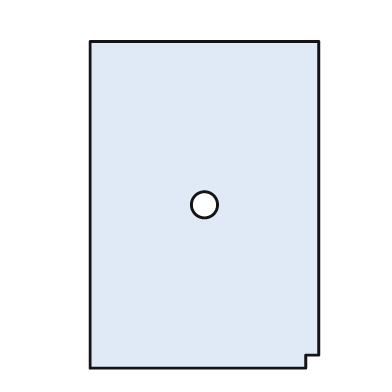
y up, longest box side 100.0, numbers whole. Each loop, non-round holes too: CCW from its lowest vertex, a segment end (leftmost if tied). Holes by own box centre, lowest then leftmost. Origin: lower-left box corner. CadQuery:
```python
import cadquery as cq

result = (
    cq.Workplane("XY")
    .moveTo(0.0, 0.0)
    .lineTo(66.0, 0.0)
    .lineTo(66.0, 4.0)
    .lineTo(70.0, 4.0)
    .lineTo(70.0, 100.0)
    .lineTo(0.0, 100.0)
    .close()
    .moveTo(35.0, 50.0)
    .circle(4.0)
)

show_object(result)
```